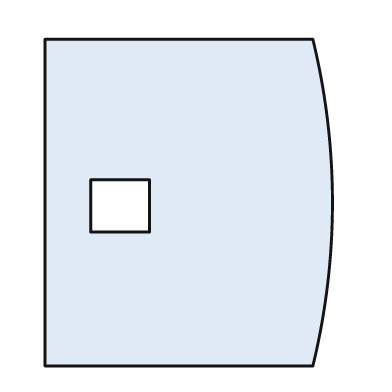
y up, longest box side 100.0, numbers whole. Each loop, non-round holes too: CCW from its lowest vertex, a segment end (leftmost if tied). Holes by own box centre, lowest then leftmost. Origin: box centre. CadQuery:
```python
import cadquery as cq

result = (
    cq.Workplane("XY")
    .moveTo(-44.0, -50.0)
    .lineTo(38.0, -50.0)
    .threePointArc((44.0, 0.0), (38.0, 50.0))
    .lineTo(-44.0, 50.0)
    .close()
    .moveTo(-30.0, -9.0)
    .lineTo(-12.0, -9.0)
    .lineTo(-12.0, 7.0)
    .lineTo(-30.0, 7.0)
    .close()
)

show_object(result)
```